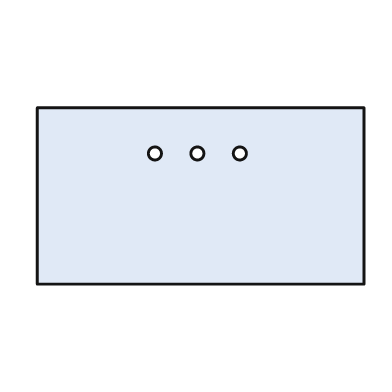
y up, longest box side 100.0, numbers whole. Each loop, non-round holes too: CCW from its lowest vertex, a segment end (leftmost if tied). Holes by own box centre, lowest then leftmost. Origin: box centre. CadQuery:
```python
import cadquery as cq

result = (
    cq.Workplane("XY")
    .moveTo(-50.0, -27.0)
    .lineTo(50.0, -27.0)
    .lineTo(50.0, 27.0)
    .lineTo(-50.0, 27.0)
    .close()
    .moveTo(-14.0, 13.0)
    .circle(2.0)
    .moveTo(-1.0, 13.0)
    .circle(2.0)
    .moveTo(12.0, 13.0)
    .circle(2.0)
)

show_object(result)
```